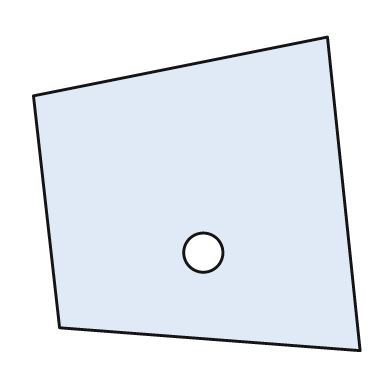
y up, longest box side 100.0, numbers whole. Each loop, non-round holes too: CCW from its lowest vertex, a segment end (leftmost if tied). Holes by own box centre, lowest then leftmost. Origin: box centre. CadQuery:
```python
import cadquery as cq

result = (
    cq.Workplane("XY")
    .moveTo(50.0, -48.0)
    .lineTo(40.0, 48.0)
    .lineTo(-50.0, 30.0)
    .lineTo(-42.0, -41.0)
    .close()
    .moveTo(2.0, -18.0)
    .circle(6.0)
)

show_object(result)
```